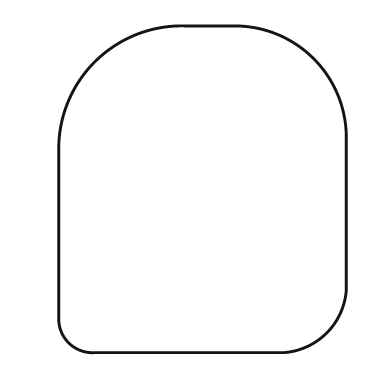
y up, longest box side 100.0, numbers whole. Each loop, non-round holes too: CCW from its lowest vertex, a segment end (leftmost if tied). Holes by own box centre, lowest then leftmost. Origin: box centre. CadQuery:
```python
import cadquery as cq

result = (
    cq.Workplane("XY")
    .moveTo(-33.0, -50.0)
    .lineTo(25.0, -50.0)
    .threePointArc((38.0, -44.0), (44.0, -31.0))
    .lineTo(44.0, 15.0)
    .threePointArc((34.0, 40.0), (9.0, 50.0))
    .lineTo(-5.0, 50.0)
    .threePointArc((-33.0, 39.0), (-44.0, 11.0))
    .lineTo(-44.0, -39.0)
    .threePointArc((-41.0, -47.0), (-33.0, -50.0))
    .close()
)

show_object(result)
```